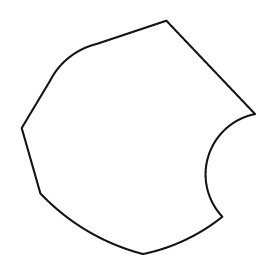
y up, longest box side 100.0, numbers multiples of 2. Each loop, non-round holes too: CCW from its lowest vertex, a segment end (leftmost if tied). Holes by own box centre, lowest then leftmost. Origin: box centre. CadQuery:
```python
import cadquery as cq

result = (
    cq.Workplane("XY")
    .moveTo(2.0, -50.0)
    .threePointArc((20.0, -44.0), (36.0, -34.0))
    .threePointArc((30.0, -8.0), (50.0, 10.0))
    .lineTo(12.0, 50.0)
    .lineTo(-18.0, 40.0)
    .threePointArc((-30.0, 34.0), (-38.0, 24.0))
    .lineTo(-50.0, 4.0)
    .lineTo(-42.0, -24.0)
    .threePointArc((-22.0, -40.0), (2.0, -50.0))
    .close()
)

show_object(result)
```